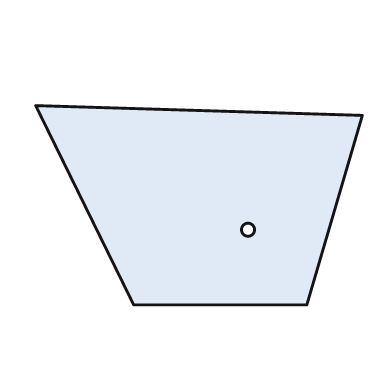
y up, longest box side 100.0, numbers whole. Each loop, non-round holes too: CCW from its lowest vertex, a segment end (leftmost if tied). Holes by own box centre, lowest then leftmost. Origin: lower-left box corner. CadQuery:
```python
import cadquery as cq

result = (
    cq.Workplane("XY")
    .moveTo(30.0, 0.0)
    .lineTo(83.0, 0.0)
    .lineTo(100.0, 58.0)
    .lineTo(0.0, 61.0)
    .close()
    .moveTo(65.0, 23.0)
    .circle(2.0)
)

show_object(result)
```